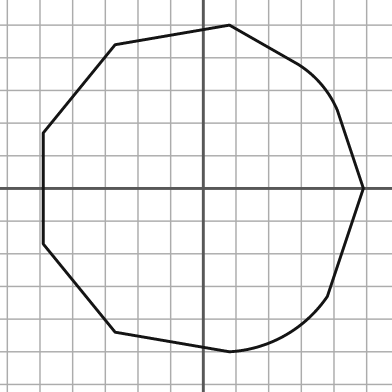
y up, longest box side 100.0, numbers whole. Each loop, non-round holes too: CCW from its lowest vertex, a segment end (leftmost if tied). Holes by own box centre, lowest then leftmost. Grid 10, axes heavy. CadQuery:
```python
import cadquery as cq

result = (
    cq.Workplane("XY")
    .moveTo(8.0, -50.0)
    .threePointArc((25.0, -45.0), (38.0, -33.0))
    .lineTo(49.0, 0.0)
    .lineTo(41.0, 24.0)
    .threePointArc((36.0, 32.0), (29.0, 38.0))
    .lineTo(8.0, 50.0)
    .lineTo(-27.0, 44.0)
    .lineTo(-49.0, 17.0)
    .lineTo(-49.0, -17.0)
    .lineTo(-27.0, -44.0)
    .close()
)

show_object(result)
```